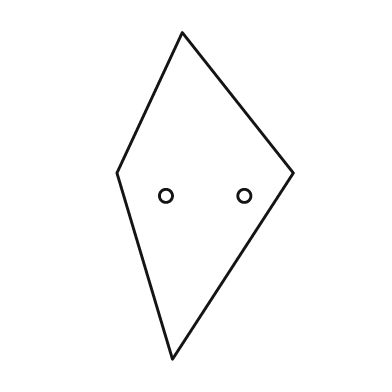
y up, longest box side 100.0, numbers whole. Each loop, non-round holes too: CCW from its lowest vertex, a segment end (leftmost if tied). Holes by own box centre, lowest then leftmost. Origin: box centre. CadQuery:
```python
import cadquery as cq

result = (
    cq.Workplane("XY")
    .moveTo(-10.0, -50.0)
    .lineTo(27.0, 7.0)
    .lineTo(-7.0, 50.0)
    .lineTo(-27.0, 7.0)
    .close()
    .moveTo(-12.0, 0.0)
    .circle(2.0)
    .moveTo(12.0, 0.0)
    .circle(2.0)
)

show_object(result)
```